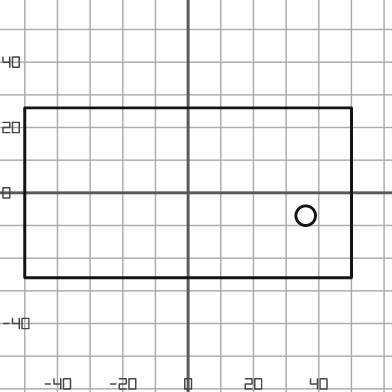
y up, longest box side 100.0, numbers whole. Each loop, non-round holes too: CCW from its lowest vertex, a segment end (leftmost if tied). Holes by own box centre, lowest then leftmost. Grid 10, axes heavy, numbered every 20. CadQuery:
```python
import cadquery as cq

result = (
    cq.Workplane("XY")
    .moveTo(-50.0, -26.0)
    .lineTo(50.0, -26.0)
    .lineTo(50.0, 26.0)
    .lineTo(-50.0, 26.0)
    .close()
    .moveTo(36.0, -7.0)
    .circle(3.0)
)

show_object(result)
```